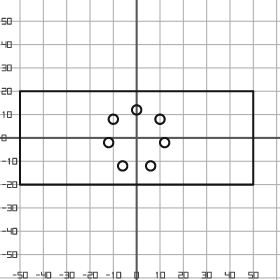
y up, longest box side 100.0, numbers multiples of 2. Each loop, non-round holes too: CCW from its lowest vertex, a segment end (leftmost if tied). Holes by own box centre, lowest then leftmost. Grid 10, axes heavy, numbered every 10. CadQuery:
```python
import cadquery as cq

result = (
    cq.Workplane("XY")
    .moveTo(-50.0, -20.0)
    .lineTo(50.0, -20.0)
    .lineTo(50.0, 20.0)
    .lineTo(-50.0, 20.0)
    .close()
    .moveTo(-6.0, -12.0)
    .circle(2.0)
    .moveTo(6.0, -12.0)
    .circle(2.0)
    .moveTo(-12.0, -2.0)
    .circle(2.0)
    .moveTo(12.0, -2.0)
    .circle(2.0)
    .moveTo(-10.0, 8.0)
    .circle(2.0)
    .moveTo(10.0, 8.0)
    .circle(2.0)
    .moveTo(0.0, 12.0)
    .circle(2.0)
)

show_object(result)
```